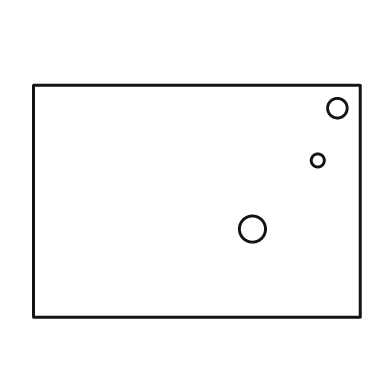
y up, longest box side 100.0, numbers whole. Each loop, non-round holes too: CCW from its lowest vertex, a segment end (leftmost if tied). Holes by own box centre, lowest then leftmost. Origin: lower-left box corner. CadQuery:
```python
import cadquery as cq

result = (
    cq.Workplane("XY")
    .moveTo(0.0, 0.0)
    .lineTo(100.0, 0.0)
    .lineTo(100.0, 71.0)
    .lineTo(0.0, 71.0)
    .close()
    .moveTo(67.0, 27.0)
    .circle(4.0)
    .moveTo(87.0, 48.0)
    .circle(2.0)
    .moveTo(93.0, 64.0)
    .circle(3.0)
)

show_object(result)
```